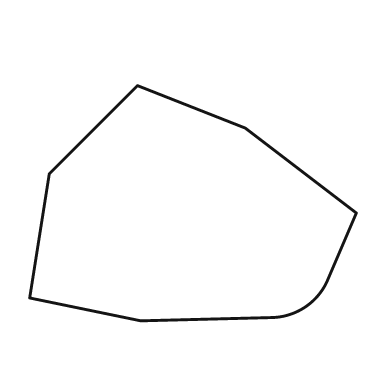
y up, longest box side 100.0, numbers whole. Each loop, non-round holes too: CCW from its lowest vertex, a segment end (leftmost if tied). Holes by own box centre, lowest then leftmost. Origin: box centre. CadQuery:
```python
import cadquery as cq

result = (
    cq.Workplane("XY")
    .moveTo(-16.0, -36.0)
    .lineTo(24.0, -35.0)
    .threePointArc((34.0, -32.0), (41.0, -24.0))
    .lineTo(50.0, -3.0)
    .lineTo(16.0, 23.0)
    .lineTo(-17.0, 36.0)
    .lineTo(-44.0, 9.0)
    .lineTo(-50.0, -29.0)
    .close()
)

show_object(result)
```